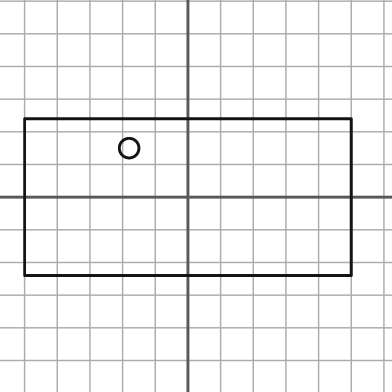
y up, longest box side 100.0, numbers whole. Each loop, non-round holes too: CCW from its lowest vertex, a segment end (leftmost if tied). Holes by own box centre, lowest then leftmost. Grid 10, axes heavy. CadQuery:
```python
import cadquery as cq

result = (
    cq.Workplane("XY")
    .moveTo(-50.0, -24.0)
    .lineTo(50.0, -24.0)
    .lineTo(50.0, 24.0)
    .lineTo(-50.0, 24.0)
    .close()
    .moveTo(-18.0, 15.0)
    .circle(3.0)
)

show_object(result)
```